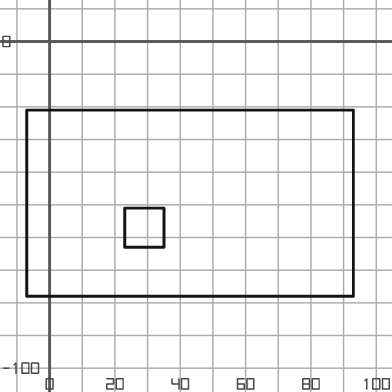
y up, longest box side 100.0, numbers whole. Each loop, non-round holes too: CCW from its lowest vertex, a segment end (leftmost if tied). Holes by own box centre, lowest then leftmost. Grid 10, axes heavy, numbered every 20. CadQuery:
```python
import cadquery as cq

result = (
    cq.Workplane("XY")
    .moveTo(-7.0, -78.0)
    .lineTo(93.0, -78.0)
    .lineTo(93.0, -21.0)
    .lineTo(-7.0, -21.0)
    .close()
    .moveTo(23.0, -63.0)
    .lineTo(35.0, -63.0)
    .lineTo(35.0, -51.0)
    .lineTo(23.0, -51.0)
    .close()
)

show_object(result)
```